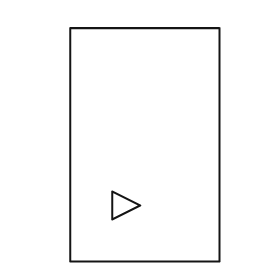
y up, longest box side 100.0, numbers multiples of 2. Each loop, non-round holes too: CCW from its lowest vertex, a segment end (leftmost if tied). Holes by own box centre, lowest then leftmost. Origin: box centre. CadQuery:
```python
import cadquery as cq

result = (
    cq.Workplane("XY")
    .moveTo(-32.0, -50.0)
    .lineTo(32.0, -50.0)
    .lineTo(32.0, 50.0)
    .lineTo(-32.0, 50.0)
    .close()
    .moveTo(-14.0, -32.0)
    .lineTo(-2.0, -26.0)
    .lineTo(-14.0, -20.0)
    .close()
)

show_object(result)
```